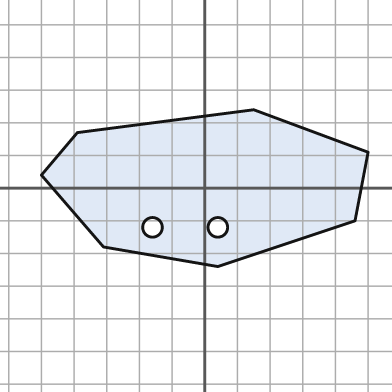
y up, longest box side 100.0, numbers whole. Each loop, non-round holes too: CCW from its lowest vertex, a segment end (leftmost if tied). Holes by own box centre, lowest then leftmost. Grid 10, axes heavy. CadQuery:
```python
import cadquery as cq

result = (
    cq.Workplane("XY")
    .moveTo(4.0, -24.0)
    .lineTo(46.0, -10.0)
    .lineTo(50.0, 11.0)
    .lineTo(15.0, 24.0)
    .lineTo(-39.0, 17.0)
    .lineTo(-50.0, 4.0)
    .lineTo(-31.0, -18.0)
    .close()
    .moveTo(-16.0, -12.0)
    .circle(3.0)
    .moveTo(4.0, -12.0)
    .circle(3.0)
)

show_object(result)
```